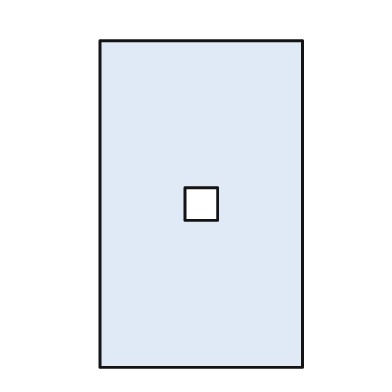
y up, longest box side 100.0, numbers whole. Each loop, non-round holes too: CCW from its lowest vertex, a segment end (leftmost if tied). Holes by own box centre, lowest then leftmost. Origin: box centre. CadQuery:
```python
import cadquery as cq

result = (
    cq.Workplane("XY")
    .moveTo(-31.0, -50.0)
    .lineTo(31.0, -50.0)
    .lineTo(31.0, 50.0)
    .lineTo(-31.0, 50.0)
    .close()
    .moveTo(-5.0, -5.0)
    .lineTo(5.0, -5.0)
    .lineTo(5.0, 5.0)
    .lineTo(-5.0, 5.0)
    .close()
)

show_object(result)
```